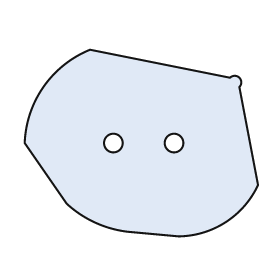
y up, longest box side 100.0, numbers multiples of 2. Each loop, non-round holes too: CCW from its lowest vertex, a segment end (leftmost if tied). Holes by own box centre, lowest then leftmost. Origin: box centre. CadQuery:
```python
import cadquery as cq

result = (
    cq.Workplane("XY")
    .moveTo(16.0, -40.0)
    .threePointArc((36.0, -34.0), (50.0, -18.0))
    .lineTo(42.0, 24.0)
    .threePointArc((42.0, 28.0), (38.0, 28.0))
    .lineTo(-22.0, 40.0)
    .threePointArc((-42.0, 24.0), (-50.0, 0.0))
    .lineTo(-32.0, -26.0)
    .threePointArc((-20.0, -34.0), (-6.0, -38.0))
    .close()
    .moveTo(-12.0, 0.0)
    .circle(4.0)
    .moveTo(14.0, 0.0)
    .circle(4.0)
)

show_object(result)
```